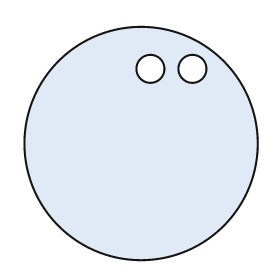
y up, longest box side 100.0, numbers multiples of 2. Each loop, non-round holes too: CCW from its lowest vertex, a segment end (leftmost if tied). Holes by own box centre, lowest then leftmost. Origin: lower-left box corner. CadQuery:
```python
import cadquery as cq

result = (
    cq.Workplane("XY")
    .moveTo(50.0, 50.0)
    .circle(50.0)
    .moveTo(54.0, 82.0)
    .circle(6.0)
    .moveTo(72.0, 82.0)
    .circle(6.0)
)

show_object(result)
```